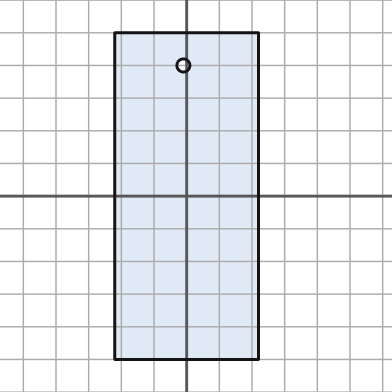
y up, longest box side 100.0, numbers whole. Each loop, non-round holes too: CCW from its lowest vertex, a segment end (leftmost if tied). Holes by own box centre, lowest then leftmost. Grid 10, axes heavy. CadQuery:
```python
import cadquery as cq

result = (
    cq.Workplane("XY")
    .moveTo(-22.0, -50.0)
    .lineTo(22.0, -50.0)
    .lineTo(22.0, 50.0)
    .lineTo(-22.0, 50.0)
    .close()
    .moveTo(-1.0, 40.0)
    .circle(2.0)
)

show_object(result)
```